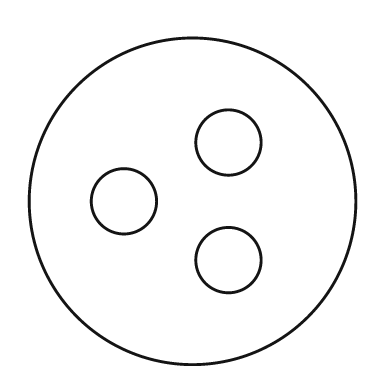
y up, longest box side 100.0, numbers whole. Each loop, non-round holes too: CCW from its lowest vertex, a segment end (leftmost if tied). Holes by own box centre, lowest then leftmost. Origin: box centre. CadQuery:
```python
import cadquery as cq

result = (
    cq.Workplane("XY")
    .moveTo(0.0, 0.0)
    .circle(50.0)
    .moveTo(11.0, -18.0)
    .circle(10.0)
    .moveTo(-21.0, 0.0)
    .circle(10.0)
    .moveTo(11.0, 18.0)
    .circle(10.0)
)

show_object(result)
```